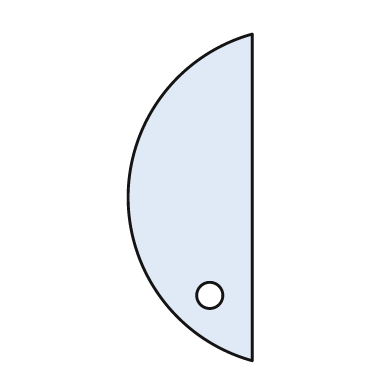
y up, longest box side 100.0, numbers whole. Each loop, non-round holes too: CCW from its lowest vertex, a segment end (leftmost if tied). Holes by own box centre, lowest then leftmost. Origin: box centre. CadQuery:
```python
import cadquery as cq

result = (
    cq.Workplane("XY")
    .moveTo(19.0, -50.0)
    .lineTo(19.0, 50.0)
    .threePointArc((-19.0, 0.0), (19.0, -50.0))
    .close()
    .moveTo(6.0, -30.0)
    .circle(4.0)
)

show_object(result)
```